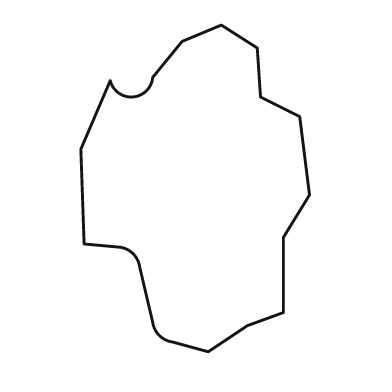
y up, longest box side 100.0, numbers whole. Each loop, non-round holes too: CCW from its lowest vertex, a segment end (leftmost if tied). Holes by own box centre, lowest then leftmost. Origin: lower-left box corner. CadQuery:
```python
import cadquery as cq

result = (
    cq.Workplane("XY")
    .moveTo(39.0, 0.0)
    .lineTo(51.0, 8.0)
    .lineTo(62.0, 12.0)
    .lineTo(62.0, 35.0)
    .lineTo(70.0, 48.0)
    .lineTo(67.0, 72.0)
    .lineTo(55.0, 78.0)
    .lineTo(54.0, 93.0)
    .lineTo(43.0, 100.0)
    .lineTo(31.0, 95.0)
    .lineTo(22.0, 84.0)
    .threePointArc((16.0, 78.0), (9.0, 83.0))
    .lineTo(0.0, 62.0)
    .lineTo(1.0, 33.0)
    .lineTo(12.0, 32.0)
    .threePointArc((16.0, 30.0), (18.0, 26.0))
    .lineTo(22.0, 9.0)
    .threePointArc((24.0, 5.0), (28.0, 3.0))
    .close()
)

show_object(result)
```